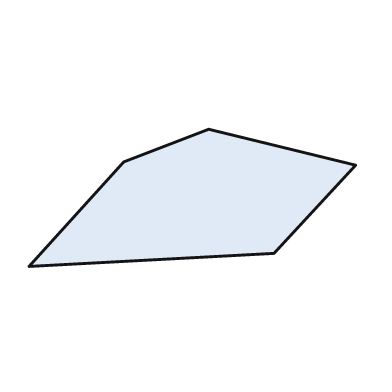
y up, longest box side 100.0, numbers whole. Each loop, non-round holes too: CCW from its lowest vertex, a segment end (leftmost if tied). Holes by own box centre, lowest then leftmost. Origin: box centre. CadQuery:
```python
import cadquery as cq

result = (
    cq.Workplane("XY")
    .moveTo(-50.0, -21.0)
    .lineTo(25.0, -17.0)
    .lineTo(50.0, 10.0)
    .lineTo(5.0, 21.0)
    .lineTo(-21.0, 11.0)
    .close()
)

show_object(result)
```